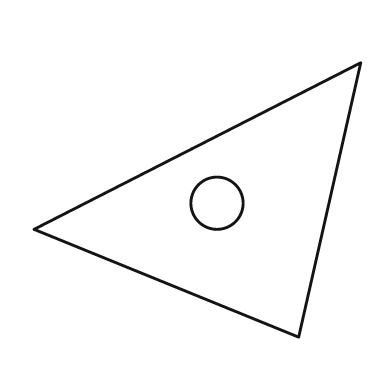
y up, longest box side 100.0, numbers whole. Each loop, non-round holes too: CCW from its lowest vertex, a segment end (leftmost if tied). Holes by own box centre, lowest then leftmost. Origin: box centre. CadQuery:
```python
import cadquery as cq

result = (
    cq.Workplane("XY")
    .moveTo(31.0, -42.0)
    .lineTo(50.0, 42.0)
    .lineTo(-50.0, -9.0)
    .close()
    .moveTo(6.0, -1.0)
    .circle(8.0)
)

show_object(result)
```